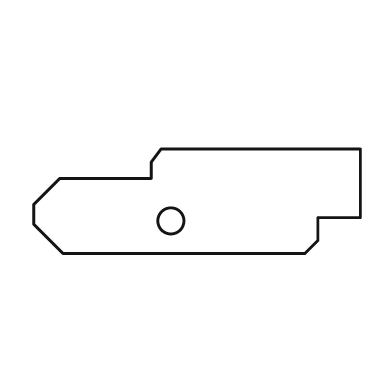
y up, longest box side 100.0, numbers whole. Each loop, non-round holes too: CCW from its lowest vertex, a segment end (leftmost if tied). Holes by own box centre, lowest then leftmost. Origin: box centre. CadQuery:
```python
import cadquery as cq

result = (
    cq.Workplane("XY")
    .moveTo(-41.0, -16.0)
    .lineTo(33.0, -16.0)
    .lineTo(37.0, -12.0)
    .lineTo(37.0, -5.0)
    .lineTo(50.0, -5.0)
    .lineTo(50.0, 16.0)
    .lineTo(-11.0, 16.0)
    .lineTo(-14.0, 12.0)
    .lineTo(-14.0, 7.0)
    .lineTo(-42.0, 7.0)
    .lineTo(-50.0, -1.0)
    .lineTo(-50.0, -7.0)
    .close()
    .moveTo(-8.0, -6.0)
    .circle(4.0)
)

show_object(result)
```